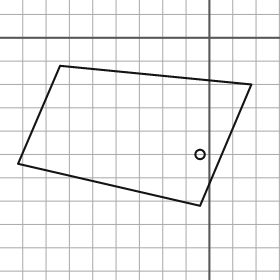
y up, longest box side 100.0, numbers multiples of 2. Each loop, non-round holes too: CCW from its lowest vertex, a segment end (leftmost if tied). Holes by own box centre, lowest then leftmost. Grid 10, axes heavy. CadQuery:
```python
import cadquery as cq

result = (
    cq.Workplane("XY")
    .moveTo(-4.0, -72.0)
    .lineTo(18.0, -20.0)
    .lineTo(-64.0, -12.0)
    .lineTo(-82.0, -54.0)
    .close()
    .moveTo(-4.0, -50.0)
    .circle(2.0)
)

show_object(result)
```